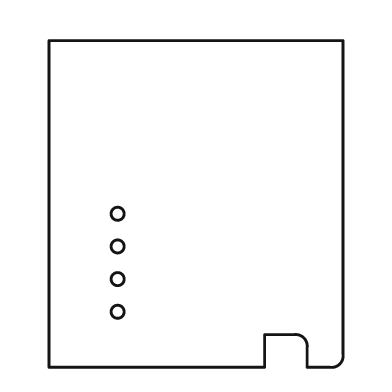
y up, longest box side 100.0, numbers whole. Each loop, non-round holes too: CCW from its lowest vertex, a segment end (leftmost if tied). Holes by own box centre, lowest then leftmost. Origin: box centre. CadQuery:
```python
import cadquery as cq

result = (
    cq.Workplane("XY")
    .moveTo(-45.0, -50.0)
    .lineTo(21.0, -50.0)
    .lineTo(21.0, -40.0)
    .lineTo(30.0, -40.0)
    .threePointArc((33.0, -41.0), (34.0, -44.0))
    .lineTo(34.0, -50.0)
    .lineTo(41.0, -50.0)
    .threePointArc((44.0, -49.0), (45.0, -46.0))
    .lineTo(45.0, 50.0)
    .lineTo(-45.0, 50.0)
    .close()
    .moveTo(-24.0, -33.0)
    .circle(2.0)
    .moveTo(-24.0, -23.0)
    .circle(2.0)
    .moveTo(-24.0, -13.0)
    .circle(2.0)
    .moveTo(-24.0, -3.0)
    .circle(2.0)
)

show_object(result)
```